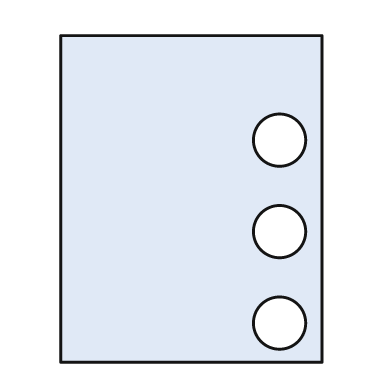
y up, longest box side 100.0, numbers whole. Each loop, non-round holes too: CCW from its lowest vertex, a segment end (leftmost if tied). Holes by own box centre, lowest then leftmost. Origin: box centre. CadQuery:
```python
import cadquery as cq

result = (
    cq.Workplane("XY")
    .moveTo(-40.0, -50.0)
    .lineTo(40.0, -50.0)
    .lineTo(40.0, 50.0)
    .lineTo(-40.0, 50.0)
    .close()
    .moveTo(27.0, -38.0)
    .circle(8.0)
    .moveTo(27.0, -10.0)
    .circle(8.0)
    .moveTo(27.0, 18.0)
    .circle(8.0)
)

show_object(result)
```